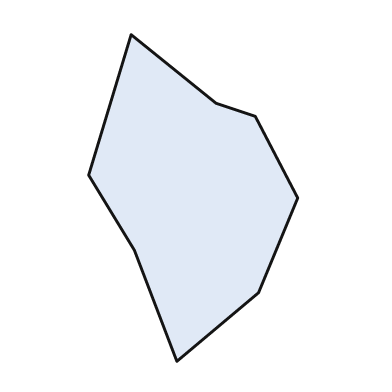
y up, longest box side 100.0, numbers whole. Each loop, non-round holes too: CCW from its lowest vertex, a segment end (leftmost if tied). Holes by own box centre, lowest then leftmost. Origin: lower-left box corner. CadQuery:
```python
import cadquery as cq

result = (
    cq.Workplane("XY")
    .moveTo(27.0, 0.0)
    .lineTo(52.0, 21.0)
    .lineTo(64.0, 50.0)
    .lineTo(51.0, 75.0)
    .lineTo(39.0, 79.0)
    .lineTo(13.0, 100.0)
    .lineTo(0.0, 57.0)
    .lineTo(14.0, 34.0)
    .close()
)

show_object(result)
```